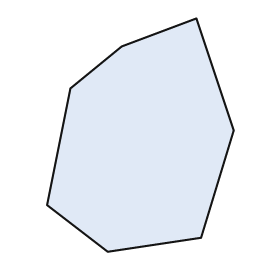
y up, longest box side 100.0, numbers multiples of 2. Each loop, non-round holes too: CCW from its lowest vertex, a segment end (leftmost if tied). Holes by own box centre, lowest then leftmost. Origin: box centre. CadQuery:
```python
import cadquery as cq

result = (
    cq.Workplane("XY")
    .moveTo(-14.0, -50.0)
    .lineTo(26.0, -44.0)
    .lineTo(40.0, 2.0)
    .lineTo(24.0, 50.0)
    .lineTo(-8.0, 38.0)
    .lineTo(-30.0, 20.0)
    .lineTo(-40.0, -30.0)
    .close()
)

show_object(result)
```